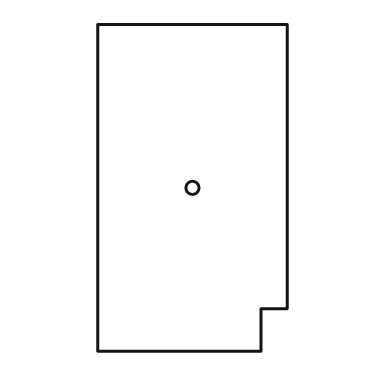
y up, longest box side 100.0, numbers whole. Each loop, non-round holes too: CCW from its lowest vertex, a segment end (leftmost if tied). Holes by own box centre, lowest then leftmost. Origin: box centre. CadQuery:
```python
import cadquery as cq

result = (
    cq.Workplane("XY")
    .moveTo(-29.0, -50.0)
    .lineTo(21.0, -50.0)
    .lineTo(21.0, -37.0)
    .lineTo(29.0, -37.0)
    .lineTo(29.0, 50.0)
    .lineTo(-29.0, 50.0)
    .close()
    .moveTo(0.0, 0.0)
    .circle(2.0)
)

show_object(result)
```